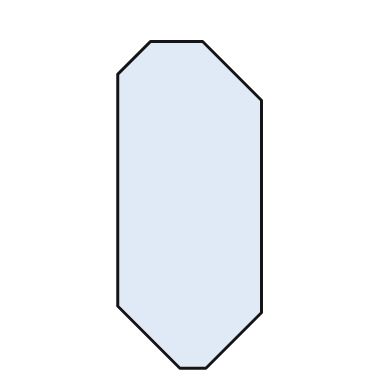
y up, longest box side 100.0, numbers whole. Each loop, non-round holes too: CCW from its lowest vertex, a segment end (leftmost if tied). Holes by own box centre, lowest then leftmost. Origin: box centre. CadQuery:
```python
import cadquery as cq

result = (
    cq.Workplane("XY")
    .moveTo(-3.0, -50.0)
    .lineTo(5.0, -50.0)
    .lineTo(22.0, -33.0)
    .lineTo(22.0, 32.0)
    .lineTo(4.0, 50.0)
    .lineTo(-12.0, 50.0)
    .lineTo(-22.0, 40.0)
    .lineTo(-22.0, -31.0)
    .close()
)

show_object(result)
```